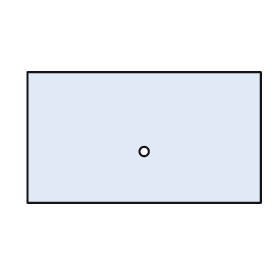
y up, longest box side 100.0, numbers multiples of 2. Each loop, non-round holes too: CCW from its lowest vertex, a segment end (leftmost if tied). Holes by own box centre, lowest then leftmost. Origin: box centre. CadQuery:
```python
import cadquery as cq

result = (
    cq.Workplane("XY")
    .moveTo(-50.0, -28.0)
    .lineTo(50.0, -28.0)
    .lineTo(50.0, 28.0)
    .lineTo(-50.0, 28.0)
    .close()
    .moveTo(0.0, -6.0)
    .circle(2.0)
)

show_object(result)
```